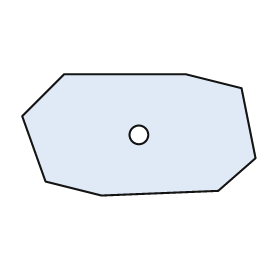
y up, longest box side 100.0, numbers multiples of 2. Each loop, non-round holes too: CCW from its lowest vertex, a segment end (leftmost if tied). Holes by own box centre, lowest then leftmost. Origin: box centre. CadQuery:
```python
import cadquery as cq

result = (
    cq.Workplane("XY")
    .moveTo(-16.0, -26.0)
    .lineTo(34.0, -24.0)
    .lineTo(50.0, -10.0)
    .lineTo(44.0, 20.0)
    .lineTo(20.0, 26.0)
    .lineTo(-32.0, 26.0)
    .lineTo(-50.0, 8.0)
    .lineTo(-40.0, -20.0)
    .close()
    .moveTo(0.0, 0.0)
    .circle(4.0)
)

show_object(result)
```